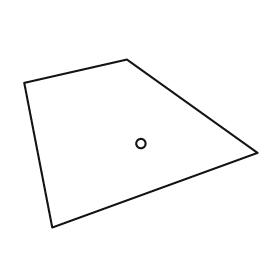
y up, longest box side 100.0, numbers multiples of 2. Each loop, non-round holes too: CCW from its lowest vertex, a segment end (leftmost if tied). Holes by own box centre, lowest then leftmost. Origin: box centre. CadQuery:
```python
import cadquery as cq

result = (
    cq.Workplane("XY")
    .moveTo(-38.0, -36.0)
    .lineTo(50.0, -4.0)
    .lineTo(-6.0, 36.0)
    .lineTo(-50.0, 26.0)
    .close()
    .moveTo(0.0, 0.0)
    .circle(2.0)
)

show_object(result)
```